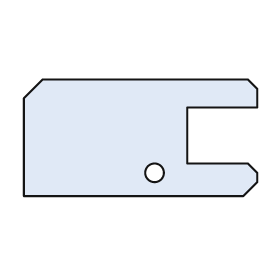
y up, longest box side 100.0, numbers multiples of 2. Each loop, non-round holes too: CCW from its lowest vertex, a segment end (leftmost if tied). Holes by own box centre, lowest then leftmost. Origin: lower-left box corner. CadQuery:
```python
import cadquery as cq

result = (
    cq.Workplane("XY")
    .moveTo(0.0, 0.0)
    .lineTo(94.0, 0.0)
    .lineTo(100.0, 6.0)
    .lineTo(100.0, 10.0)
    .lineTo(96.0, 14.0)
    .lineTo(70.0, 14.0)
    .lineTo(70.0, 38.0)
    .lineTo(100.0, 38.0)
    .lineTo(100.0, 46.0)
    .lineTo(96.0, 50.0)
    .lineTo(8.0, 50.0)
    .lineTo(0.0, 42.0)
    .close()
    .moveTo(56.0, 10.0)
    .circle(4.0)
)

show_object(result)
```